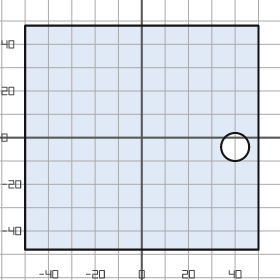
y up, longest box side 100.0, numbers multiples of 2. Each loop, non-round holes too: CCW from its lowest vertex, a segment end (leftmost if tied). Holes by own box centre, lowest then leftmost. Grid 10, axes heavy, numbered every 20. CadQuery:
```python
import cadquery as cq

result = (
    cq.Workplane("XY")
    .moveTo(-50.0, -48.0)
    .lineTo(50.0, -48.0)
    .lineTo(50.0, 48.0)
    .lineTo(-50.0, 48.0)
    .close()
    .moveTo(40.0, -4.0)
    .circle(6.0)
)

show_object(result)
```